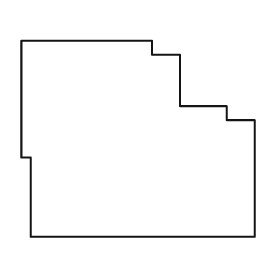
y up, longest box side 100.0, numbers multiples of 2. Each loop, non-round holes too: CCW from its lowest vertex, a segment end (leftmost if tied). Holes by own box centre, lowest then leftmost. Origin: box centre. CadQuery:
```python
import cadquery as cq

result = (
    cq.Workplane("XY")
    .moveTo(-46.0, -42.0)
    .lineTo(50.0, -42.0)
    .lineTo(50.0, 8.0)
    .lineTo(38.0, 8.0)
    .lineTo(38.0, 14.0)
    .lineTo(18.0, 14.0)
    .lineTo(18.0, 36.0)
    .lineTo(6.0, 36.0)
    .lineTo(6.0, 42.0)
    .lineTo(-50.0, 42.0)
    .lineTo(-50.0, -8.0)
    .lineTo(-46.0, -8.0)
    .close()
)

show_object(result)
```